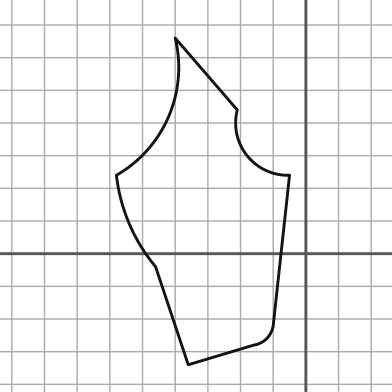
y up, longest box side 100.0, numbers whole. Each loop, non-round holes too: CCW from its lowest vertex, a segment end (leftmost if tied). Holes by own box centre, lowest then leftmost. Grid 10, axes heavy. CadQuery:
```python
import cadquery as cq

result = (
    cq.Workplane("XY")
    .moveTo(-36.0, -34.0)
    .lineTo(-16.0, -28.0)
    .threePointArc((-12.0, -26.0), (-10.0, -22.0))
    .lineTo(-5.0, 24.0)
    .threePointArc((-18.0, 30.0), (-21.0, 44.0))
    .lineTo(-40.0, 66.0)
    .threePointArc((-42.0, 42.0), (-58.0, 24.0))
    .threePointArc((-54.0, 9.0), (-46.0, -4.0))
    .close()
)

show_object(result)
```